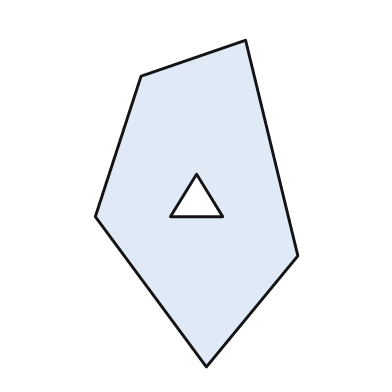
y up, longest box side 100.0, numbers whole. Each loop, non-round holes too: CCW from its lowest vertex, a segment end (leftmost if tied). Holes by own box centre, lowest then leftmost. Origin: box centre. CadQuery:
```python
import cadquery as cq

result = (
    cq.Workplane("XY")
    .moveTo(3.0, -50.0)
    .lineTo(31.0, -16.0)
    .lineTo(15.0, 50.0)
    .lineTo(-17.0, 39.0)
    .lineTo(-31.0, -4.0)
    .close()
    .moveTo(-8.0, -4.0)
    .lineTo(8.0, -4.0)
    .lineTo(0.0, 9.0)
    .close()
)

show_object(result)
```